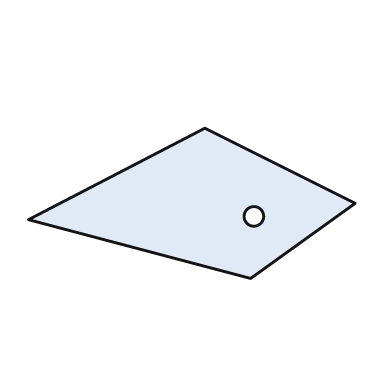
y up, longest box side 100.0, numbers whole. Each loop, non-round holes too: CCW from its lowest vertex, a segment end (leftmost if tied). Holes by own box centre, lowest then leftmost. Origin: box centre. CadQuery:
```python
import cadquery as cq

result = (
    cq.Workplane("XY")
    .moveTo(18.0, -23.0)
    .lineTo(50.0, 0.0)
    .lineTo(4.0, 23.0)
    .lineTo(-50.0, -5.0)
    .close()
    .moveTo(19.0, -4.0)
    .circle(3.0)
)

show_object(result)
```